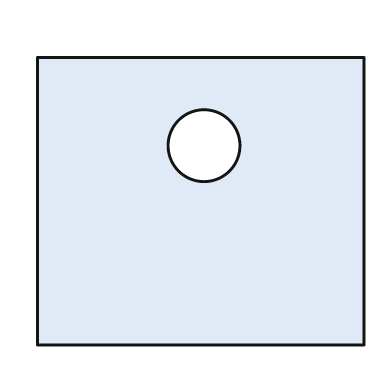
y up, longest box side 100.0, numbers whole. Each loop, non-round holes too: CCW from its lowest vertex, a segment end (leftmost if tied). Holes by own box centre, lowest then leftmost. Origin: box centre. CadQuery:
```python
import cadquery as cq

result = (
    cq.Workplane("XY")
    .moveTo(-50.0, -44.0)
    .lineTo(50.0, -44.0)
    .lineTo(50.0, 44.0)
    .lineTo(-50.0, 44.0)
    .close()
    .moveTo(1.0, 17.0)
    .circle(11.0)
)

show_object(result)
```